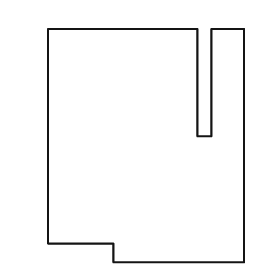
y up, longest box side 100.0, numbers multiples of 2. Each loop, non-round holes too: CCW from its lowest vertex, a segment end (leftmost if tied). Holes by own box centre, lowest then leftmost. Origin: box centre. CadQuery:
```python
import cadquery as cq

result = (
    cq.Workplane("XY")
    .moveTo(-14.0, -50.0)
    .lineTo(42.0, -50.0)
    .lineTo(42.0, 50.0)
    .lineTo(28.0, 50.0)
    .lineTo(28.0, 4.0)
    .lineTo(22.0, 4.0)
    .lineTo(22.0, 50.0)
    .lineTo(-42.0, 50.0)
    .lineTo(-42.0, -42.0)
    .lineTo(-14.0, -42.0)
    .close()
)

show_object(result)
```